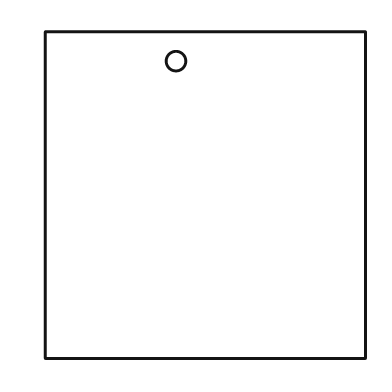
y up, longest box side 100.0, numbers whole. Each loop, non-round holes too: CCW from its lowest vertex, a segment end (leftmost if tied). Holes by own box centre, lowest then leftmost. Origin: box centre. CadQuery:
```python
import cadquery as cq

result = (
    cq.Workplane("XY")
    .moveTo(-49.0, -50.0)
    .lineTo(49.0, -50.0)
    .lineTo(49.0, 50.0)
    .lineTo(-49.0, 50.0)
    .close()
    .moveTo(-9.0, 41.0)
    .circle(3.0)
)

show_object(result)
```